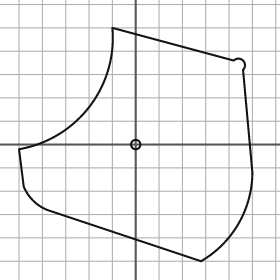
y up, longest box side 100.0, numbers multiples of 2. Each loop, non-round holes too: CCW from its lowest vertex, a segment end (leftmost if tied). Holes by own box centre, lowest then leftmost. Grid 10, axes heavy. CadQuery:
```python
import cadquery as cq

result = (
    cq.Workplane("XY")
    .moveTo(28.0, -50.0)
    .threePointArc((44.0, -34.0), (50.0, -12.0))
    .lineTo(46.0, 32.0)
    .threePointArc((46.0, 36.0), (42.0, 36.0))
    .lineTo(-10.0, 50.0)
    .threePointArc((-20.0, 16.0), (-50.0, -2.0))
    .lineTo(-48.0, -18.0)
    .threePointArc((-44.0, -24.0), (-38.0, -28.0))
    .close()
    .moveTo(0.0, 0.0)
    .circle(2.0)
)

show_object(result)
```